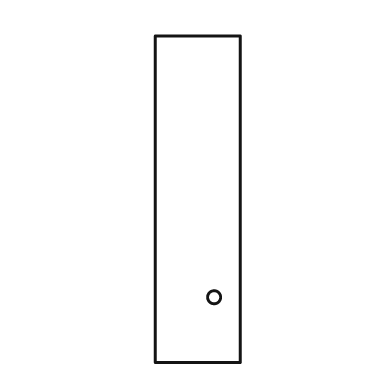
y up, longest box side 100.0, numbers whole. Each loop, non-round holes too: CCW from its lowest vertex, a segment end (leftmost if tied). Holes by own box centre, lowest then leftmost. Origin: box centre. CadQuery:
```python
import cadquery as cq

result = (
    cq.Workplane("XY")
    .moveTo(-13.0, -50.0)
    .lineTo(13.0, -50.0)
    .lineTo(13.0, 50.0)
    .lineTo(-13.0, 50.0)
    .close()
    .moveTo(5.0, -30.0)
    .circle(2.0)
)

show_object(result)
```